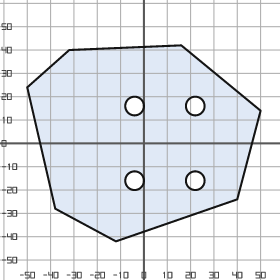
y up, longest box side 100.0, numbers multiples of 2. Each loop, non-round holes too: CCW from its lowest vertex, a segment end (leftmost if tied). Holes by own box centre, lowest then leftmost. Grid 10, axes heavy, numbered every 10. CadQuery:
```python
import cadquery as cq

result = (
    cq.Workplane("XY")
    .moveTo(-12.0, -42.0)
    .lineTo(40.0, -24.0)
    .lineTo(50.0, 14.0)
    .lineTo(16.0, 42.0)
    .lineTo(-32.0, 40.0)
    .lineTo(-50.0, 24.0)
    .lineTo(-38.0, -28.0)
    .close()
    .moveTo(-4.0, -16.0)
    .circle(4.0)
    .moveTo(22.0, -16.0)
    .circle(4.0)
    .moveTo(-4.0, 16.0)
    .circle(4.0)
    .moveTo(22.0, 16.0)
    .circle(4.0)
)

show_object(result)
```